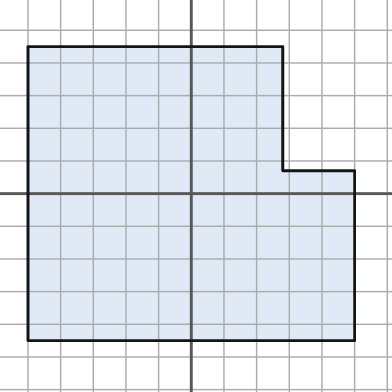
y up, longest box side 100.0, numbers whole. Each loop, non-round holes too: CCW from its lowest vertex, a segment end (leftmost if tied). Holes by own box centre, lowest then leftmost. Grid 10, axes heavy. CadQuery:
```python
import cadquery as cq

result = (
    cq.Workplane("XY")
    .moveTo(-50.0, -45.0)
    .lineTo(50.0, -45.0)
    .lineTo(50.0, 7.0)
    .lineTo(28.0, 7.0)
    .lineTo(28.0, 45.0)
    .lineTo(-50.0, 45.0)
    .close()
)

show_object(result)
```